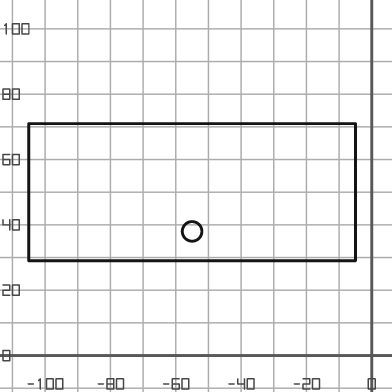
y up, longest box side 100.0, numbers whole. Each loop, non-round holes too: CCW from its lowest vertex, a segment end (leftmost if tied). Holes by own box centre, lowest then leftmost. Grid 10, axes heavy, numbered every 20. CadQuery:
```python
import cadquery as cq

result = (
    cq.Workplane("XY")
    .moveTo(-105.0, 29.0)
    .lineTo(-5.0, 29.0)
    .lineTo(-5.0, 71.0)
    .lineTo(-105.0, 71.0)
    .close()
    .moveTo(-55.0, 38.0)
    .circle(3.0)
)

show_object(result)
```